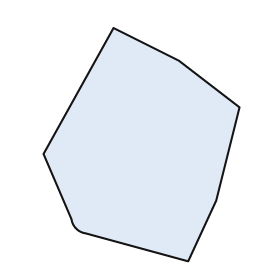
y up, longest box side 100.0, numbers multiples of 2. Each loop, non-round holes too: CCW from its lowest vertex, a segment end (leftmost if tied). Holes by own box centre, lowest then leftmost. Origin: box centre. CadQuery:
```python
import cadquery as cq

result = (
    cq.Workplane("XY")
    .moveTo(20.0, -50.0)
    .lineTo(32.0, -24.0)
    .lineTo(42.0, 16.0)
    .lineTo(16.0, 36.0)
    .lineTo(-12.0, 50.0)
    .lineTo(-42.0, -4.0)
    .lineTo(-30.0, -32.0)
    .threePointArc((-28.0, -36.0), (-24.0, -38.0))
    .close()
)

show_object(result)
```